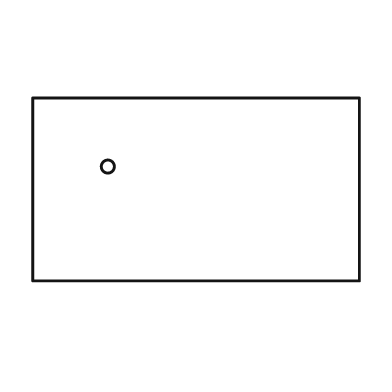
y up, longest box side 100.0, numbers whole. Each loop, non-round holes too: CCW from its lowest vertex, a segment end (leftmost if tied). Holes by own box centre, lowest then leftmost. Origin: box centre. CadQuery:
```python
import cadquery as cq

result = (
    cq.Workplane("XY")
    .moveTo(-50.0, -28.0)
    .lineTo(50.0, -28.0)
    .lineTo(50.0, 28.0)
    .lineTo(-50.0, 28.0)
    .close()
    .moveTo(-27.0, 7.0)
    .circle(2.0)
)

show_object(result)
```